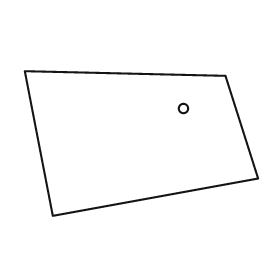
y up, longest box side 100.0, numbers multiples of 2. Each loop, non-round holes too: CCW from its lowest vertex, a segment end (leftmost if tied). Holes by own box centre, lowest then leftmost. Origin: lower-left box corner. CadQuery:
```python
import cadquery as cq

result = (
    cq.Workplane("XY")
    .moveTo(12.0, 0.0)
    .lineTo(100.0, 16.0)
    .lineTo(86.0, 60.0)
    .lineTo(0.0, 62.0)
    .close()
    .moveTo(68.0, 46.0)
    .circle(2.0)
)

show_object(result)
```